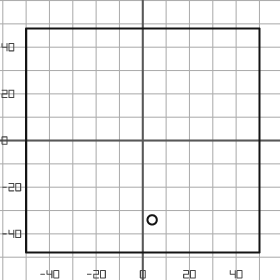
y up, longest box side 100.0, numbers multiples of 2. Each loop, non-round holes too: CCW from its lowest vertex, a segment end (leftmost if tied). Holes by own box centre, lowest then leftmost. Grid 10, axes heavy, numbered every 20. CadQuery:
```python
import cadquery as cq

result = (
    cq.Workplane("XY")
    .moveTo(-50.0, -48.0)
    .lineTo(50.0, -48.0)
    .lineTo(50.0, 48.0)
    .lineTo(-50.0, 48.0)
    .close()
    .moveTo(4.0, -34.0)
    .circle(2.0)
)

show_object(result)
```